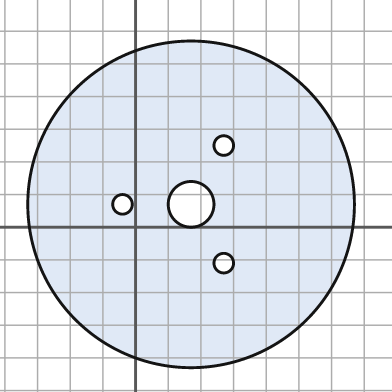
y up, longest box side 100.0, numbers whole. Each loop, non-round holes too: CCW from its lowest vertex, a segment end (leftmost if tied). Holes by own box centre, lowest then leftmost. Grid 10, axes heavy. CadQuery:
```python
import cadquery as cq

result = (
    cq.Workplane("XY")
    .moveTo(17.0, 7.0)
    .circle(50.0)
    .moveTo(27.0, -11.0)
    .circle(3.0)
    .moveTo(-4.0, 7.0)
    .circle(3.0)
    .moveTo(17.0, 7.0)
    .circle(7.0)
    .moveTo(27.0, 25.0)
    .circle(3.0)
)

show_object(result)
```